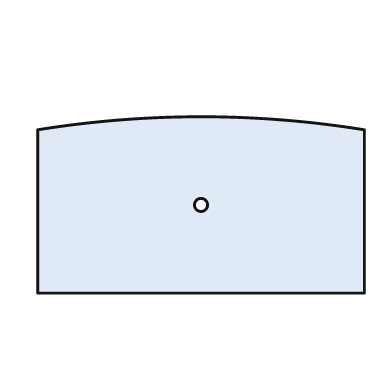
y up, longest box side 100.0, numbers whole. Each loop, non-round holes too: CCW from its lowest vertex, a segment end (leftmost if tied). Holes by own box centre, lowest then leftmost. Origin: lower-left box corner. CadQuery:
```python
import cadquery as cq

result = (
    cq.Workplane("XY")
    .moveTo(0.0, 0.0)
    .lineTo(100.0, 0.0)
    .lineTo(100.0, 50.0)
    .threePointArc((50.0, 54.0), (0.0, 50.0))
    .close()
    .moveTo(50.0, 27.0)
    .circle(2.0)
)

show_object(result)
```